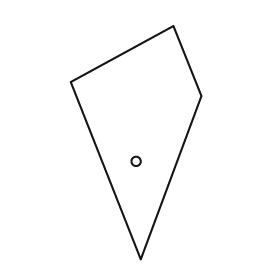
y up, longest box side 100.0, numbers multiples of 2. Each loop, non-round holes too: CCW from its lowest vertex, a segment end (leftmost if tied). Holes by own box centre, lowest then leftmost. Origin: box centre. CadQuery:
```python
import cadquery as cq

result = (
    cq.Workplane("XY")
    .moveTo(2.0, -50.0)
    .lineTo(28.0, 20.0)
    .lineTo(16.0, 50.0)
    .lineTo(-28.0, 26.0)
    .close()
    .moveTo(0.0, -8.0)
    .circle(2.0)
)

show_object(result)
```